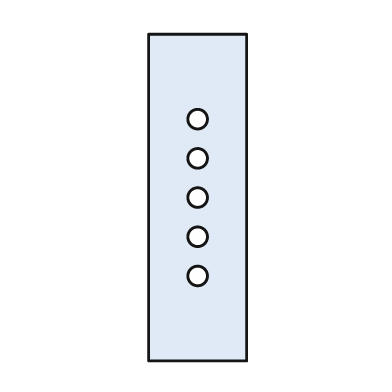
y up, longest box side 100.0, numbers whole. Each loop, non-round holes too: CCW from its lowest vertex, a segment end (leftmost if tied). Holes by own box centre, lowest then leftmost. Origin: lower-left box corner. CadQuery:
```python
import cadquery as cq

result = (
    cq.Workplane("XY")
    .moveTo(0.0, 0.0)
    .lineTo(30.0, 0.0)
    .lineTo(30.0, 100.0)
    .lineTo(0.0, 100.0)
    .close()
    .moveTo(15.0, 26.0)
    .circle(3.0)
    .moveTo(15.0, 38.0)
    .circle(3.0)
    .moveTo(15.0, 50.0)
    .circle(3.0)
    .moveTo(15.0, 62.0)
    .circle(3.0)
    .moveTo(15.0, 74.0)
    .circle(3.0)
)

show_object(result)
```